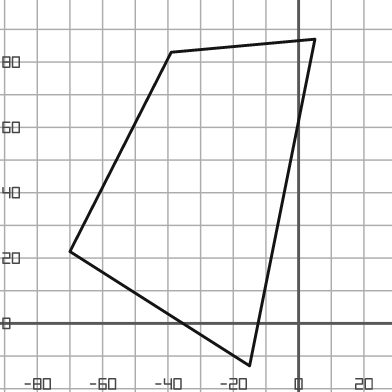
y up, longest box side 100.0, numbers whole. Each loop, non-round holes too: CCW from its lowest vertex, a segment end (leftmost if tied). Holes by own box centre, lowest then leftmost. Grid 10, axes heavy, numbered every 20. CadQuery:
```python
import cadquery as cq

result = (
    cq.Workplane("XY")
    .moveTo(-15.0, -13.0)
    .lineTo(5.0, 87.0)
    .lineTo(-39.0, 83.0)
    .lineTo(-70.0, 22.0)
    .close()
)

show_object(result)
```